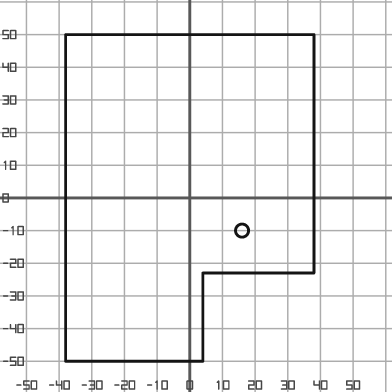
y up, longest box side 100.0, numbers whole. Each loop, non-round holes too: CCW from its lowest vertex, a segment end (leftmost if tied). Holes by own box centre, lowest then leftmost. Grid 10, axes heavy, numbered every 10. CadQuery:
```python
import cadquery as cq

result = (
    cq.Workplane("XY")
    .moveTo(-38.0, -50.0)
    .lineTo(4.0, -50.0)
    .lineTo(4.0, -23.0)
    .lineTo(38.0, -23.0)
    .lineTo(38.0, 50.0)
    .lineTo(-38.0, 50.0)
    .close()
    .moveTo(16.0, -10.0)
    .circle(2.0)
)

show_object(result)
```